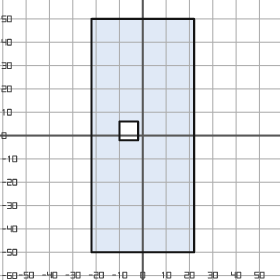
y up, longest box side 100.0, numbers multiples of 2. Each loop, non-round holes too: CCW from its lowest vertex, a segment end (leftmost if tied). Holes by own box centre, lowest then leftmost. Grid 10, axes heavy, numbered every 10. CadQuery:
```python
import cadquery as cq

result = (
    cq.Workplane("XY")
    .moveTo(-22.0, -50.0)
    .lineTo(22.0, -50.0)
    .lineTo(22.0, 50.0)
    .lineTo(-22.0, 50.0)
    .close()
    .moveTo(-10.0, -2.0)
    .lineTo(-2.0, -2.0)
    .lineTo(-2.0, 6.0)
    .lineTo(-10.0, 6.0)
    .close()
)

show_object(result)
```